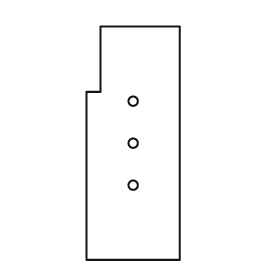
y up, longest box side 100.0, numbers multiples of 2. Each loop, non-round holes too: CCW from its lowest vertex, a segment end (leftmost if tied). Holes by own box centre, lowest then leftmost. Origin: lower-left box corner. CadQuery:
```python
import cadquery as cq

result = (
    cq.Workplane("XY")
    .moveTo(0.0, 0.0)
    .lineTo(40.0, 0.0)
    .lineTo(40.0, 100.0)
    .lineTo(6.0, 100.0)
    .lineTo(6.0, 72.0)
    .lineTo(0.0, 72.0)
    .close()
    .moveTo(20.0, 32.0)
    .circle(2.0)
    .moveTo(20.0, 50.0)
    .circle(2.0)
    .moveTo(20.0, 68.0)
    .circle(2.0)
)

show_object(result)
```